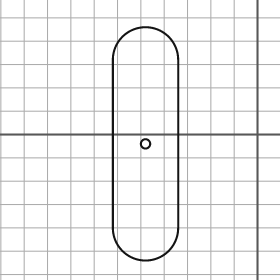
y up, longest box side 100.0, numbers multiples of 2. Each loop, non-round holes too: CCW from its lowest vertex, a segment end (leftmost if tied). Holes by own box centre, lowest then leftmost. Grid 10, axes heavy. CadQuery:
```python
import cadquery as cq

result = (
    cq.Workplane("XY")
    .moveTo(-62.0, -40.0)
    .threePointArc((-48.0, -54.0), (-34.0, -40.0))
    .lineTo(-34.0, 32.0)
    .threePointArc((-48.0, 46.0), (-62.0, 32.0))
    .close()
    .moveTo(-48.0, -4.0)
    .circle(2.0)
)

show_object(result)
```